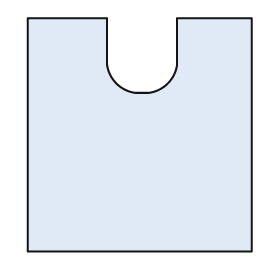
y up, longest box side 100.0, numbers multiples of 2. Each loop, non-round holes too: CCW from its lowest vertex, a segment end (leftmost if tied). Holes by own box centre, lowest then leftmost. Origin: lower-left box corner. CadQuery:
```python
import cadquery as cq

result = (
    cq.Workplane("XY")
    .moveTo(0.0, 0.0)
    .lineTo(96.0, 0.0)
    .lineTo(96.0, 100.0)
    .lineTo(64.0, 100.0)
    .lineTo(64.0, 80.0)
    .threePointArc((60.0, 72.0), (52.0, 68.0))
    .lineTo(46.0, 68.0)
    .threePointArc((38.0, 72.0), (34.0, 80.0))
    .lineTo(34.0, 100.0)
    .lineTo(0.0, 100.0)
    .close()
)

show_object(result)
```